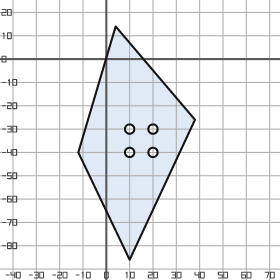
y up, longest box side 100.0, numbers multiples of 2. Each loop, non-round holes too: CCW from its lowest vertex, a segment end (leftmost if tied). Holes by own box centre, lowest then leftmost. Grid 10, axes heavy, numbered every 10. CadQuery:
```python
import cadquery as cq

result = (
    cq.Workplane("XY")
    .moveTo(10.0, -86.0)
    .lineTo(38.0, -26.0)
    .lineTo(4.0, 14.0)
    .lineTo(-12.0, -40.0)
    .close()
    .moveTo(10.0, -40.0)
    .circle(2.0)
    .moveTo(20.0, -40.0)
    .circle(2.0)
    .moveTo(10.0, -30.0)
    .circle(2.0)
    .moveTo(20.0, -30.0)
    .circle(2.0)
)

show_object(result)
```